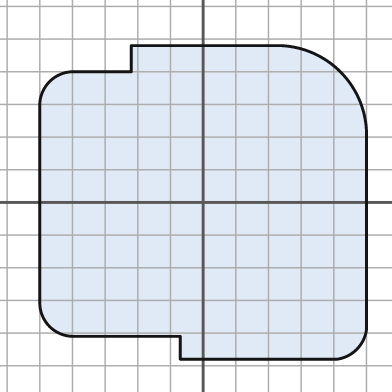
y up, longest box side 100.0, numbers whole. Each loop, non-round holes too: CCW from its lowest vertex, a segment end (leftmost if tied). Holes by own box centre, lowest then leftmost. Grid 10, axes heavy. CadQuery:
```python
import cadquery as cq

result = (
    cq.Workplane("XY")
    .moveTo(-7.0, -48.0)
    .lineTo(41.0, -48.0)
    .threePointArc((47.0, -45.0), (50.0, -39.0))
    .lineTo(50.0, 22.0)
    .threePointArc((42.0, 40.0), (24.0, 48.0))
    .lineTo(-22.0, 48.0)
    .lineTo(-22.0, 40.0)
    .lineTo(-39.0, 40.0)
    .threePointArc((-47.0, 37.0), (-50.0, 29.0))
    .lineTo(-50.0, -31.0)
    .threePointArc((-47.0, -38.0), (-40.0, -41.0))
    .lineTo(-7.0, -41.0)
    .close()
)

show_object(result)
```